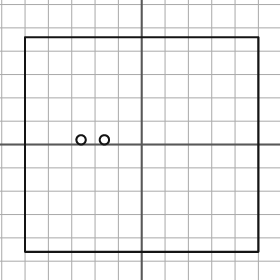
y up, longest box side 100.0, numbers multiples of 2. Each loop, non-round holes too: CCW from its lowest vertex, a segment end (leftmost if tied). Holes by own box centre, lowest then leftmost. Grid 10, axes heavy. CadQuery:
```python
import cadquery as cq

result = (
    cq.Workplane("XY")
    .moveTo(-50.0, -46.0)
    .lineTo(50.0, -46.0)
    .lineTo(50.0, 46.0)
    .lineTo(-50.0, 46.0)
    .close()
    .moveTo(-26.0, 2.0)
    .circle(2.0)
    .moveTo(-16.0, 2.0)
    .circle(2.0)
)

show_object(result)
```